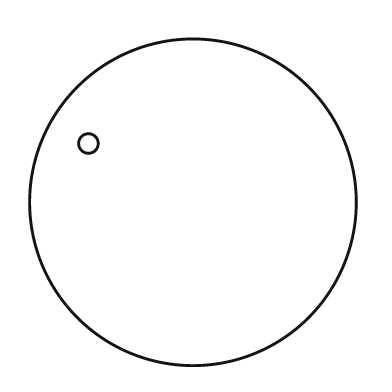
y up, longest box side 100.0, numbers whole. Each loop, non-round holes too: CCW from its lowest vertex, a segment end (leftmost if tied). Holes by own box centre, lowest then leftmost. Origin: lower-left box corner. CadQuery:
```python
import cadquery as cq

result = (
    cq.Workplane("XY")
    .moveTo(50.0, 50.0)
    .circle(50.0)
    .moveTo(18.0, 68.0)
    .circle(3.0)
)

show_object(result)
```